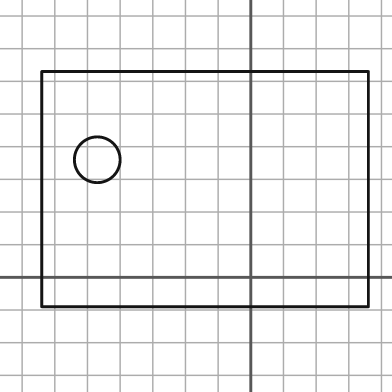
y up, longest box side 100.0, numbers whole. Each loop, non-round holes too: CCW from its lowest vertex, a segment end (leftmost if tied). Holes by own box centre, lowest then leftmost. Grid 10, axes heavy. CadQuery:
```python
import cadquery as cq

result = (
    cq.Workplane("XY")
    .moveTo(-64.0, -9.0)
    .lineTo(36.0, -9.0)
    .lineTo(36.0, 63.0)
    .lineTo(-64.0, 63.0)
    .close()
    .moveTo(-47.0, 36.0)
    .circle(7.0)
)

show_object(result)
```